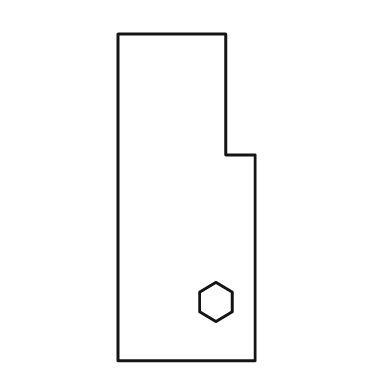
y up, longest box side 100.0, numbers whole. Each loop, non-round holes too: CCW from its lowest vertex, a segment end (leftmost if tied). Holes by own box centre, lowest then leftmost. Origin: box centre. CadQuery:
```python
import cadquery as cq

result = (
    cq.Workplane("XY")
    .moveTo(-21.0, -50.0)
    .lineTo(21.0, -50.0)
    .lineTo(21.0, 13.0)
    .lineTo(12.0, 13.0)
    .lineTo(12.0, 50.0)
    .lineTo(-21.0, 50.0)
    .close()
    .moveTo(9.0, -38.0)
    .lineTo(14.0, -35.0)
    .lineTo(14.0, -29.0)
    .lineTo(9.0, -26.0)
    .lineTo(4.0, -29.0)
    .lineTo(4.0, -35.0)
    .close()
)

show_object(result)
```